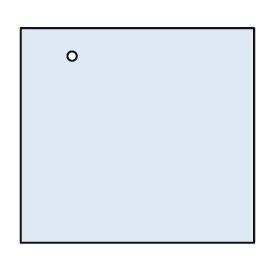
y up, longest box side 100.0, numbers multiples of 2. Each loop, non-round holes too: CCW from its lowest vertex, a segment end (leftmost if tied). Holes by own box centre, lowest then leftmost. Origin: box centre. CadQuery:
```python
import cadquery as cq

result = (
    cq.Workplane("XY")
    .moveTo(-50.0, -46.0)
    .lineTo(50.0, -46.0)
    .lineTo(50.0, 46.0)
    .lineTo(-50.0, 46.0)
    .close()
    .moveTo(-28.0, 34.0)
    .circle(2.0)
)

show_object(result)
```